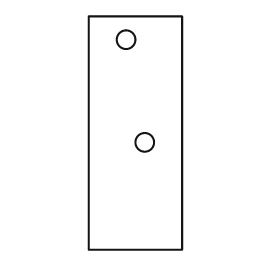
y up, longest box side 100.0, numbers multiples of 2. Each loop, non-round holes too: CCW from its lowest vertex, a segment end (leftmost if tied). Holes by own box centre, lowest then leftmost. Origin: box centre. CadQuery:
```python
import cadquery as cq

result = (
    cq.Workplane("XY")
    .moveTo(-20.0, -50.0)
    .lineTo(20.0, -50.0)
    .lineTo(20.0, 50.0)
    .lineTo(-20.0, 50.0)
    .close()
    .moveTo(4.0, -4.0)
    .circle(4.0)
    .moveTo(-4.0, 40.0)
    .circle(4.0)
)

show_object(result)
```